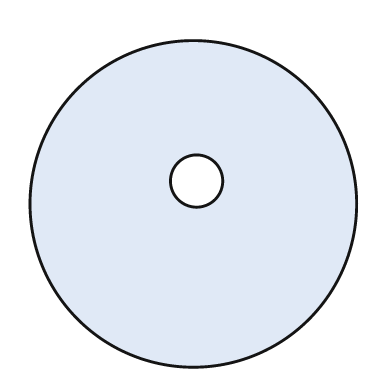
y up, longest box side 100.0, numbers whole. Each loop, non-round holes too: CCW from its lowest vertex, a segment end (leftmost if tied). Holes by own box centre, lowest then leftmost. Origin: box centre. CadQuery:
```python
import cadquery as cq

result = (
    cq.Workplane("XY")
    .moveTo(0.0, 0.0)
    .circle(50.0)
    .moveTo(1.0, 7.0)
    .circle(8.0)
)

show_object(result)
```